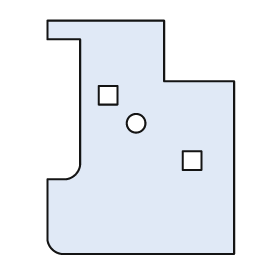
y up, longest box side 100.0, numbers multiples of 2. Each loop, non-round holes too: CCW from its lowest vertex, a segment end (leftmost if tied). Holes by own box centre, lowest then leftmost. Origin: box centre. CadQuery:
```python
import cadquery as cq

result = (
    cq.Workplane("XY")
    .moveTo(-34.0, -50.0)
    .lineTo(40.0, -50.0)
    .lineTo(40.0, 24.0)
    .lineTo(10.0, 24.0)
    .lineTo(10.0, 50.0)
    .lineTo(-40.0, 50.0)
    .lineTo(-40.0, 42.0)
    .lineTo(-26.0, 42.0)
    .lineTo(-26.0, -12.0)
    .threePointArc((-28.0, -16.0), (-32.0, -18.0))
    .lineTo(-40.0, -18.0)
    .lineTo(-40.0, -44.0)
    .threePointArc((-38.0, -48.0), (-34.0, -50.0))
    .close()
    .moveTo(18.0, -14.0)
    .lineTo(26.0, -14.0)
    .lineTo(26.0, -6.0)
    .lineTo(18.0, -6.0)
    .close()
    .moveTo(-2.0, 6.0)
    .circle(4.0)
    .moveTo(-18.0, 14.0)
    .lineTo(-10.0, 14.0)
    .lineTo(-10.0, 22.0)
    .lineTo(-18.0, 22.0)
    .close()
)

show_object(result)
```